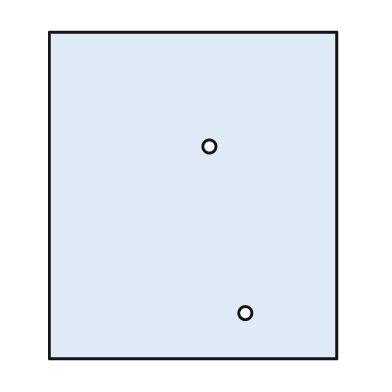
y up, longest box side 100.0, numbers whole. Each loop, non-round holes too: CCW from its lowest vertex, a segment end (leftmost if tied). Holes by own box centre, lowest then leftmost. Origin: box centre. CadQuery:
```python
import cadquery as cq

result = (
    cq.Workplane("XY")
    .moveTo(-44.0, -50.0)
    .lineTo(44.0, -50.0)
    .lineTo(44.0, 50.0)
    .lineTo(-44.0, 50.0)
    .close()
    .moveTo(16.0, -36.0)
    .circle(2.0)
    .moveTo(5.0, 15.0)
    .circle(2.0)
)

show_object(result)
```